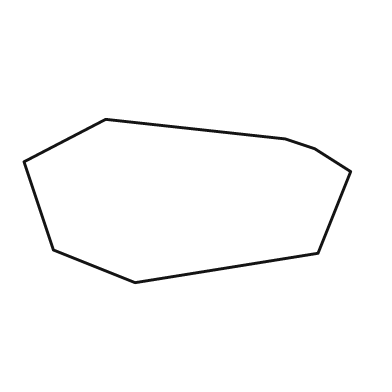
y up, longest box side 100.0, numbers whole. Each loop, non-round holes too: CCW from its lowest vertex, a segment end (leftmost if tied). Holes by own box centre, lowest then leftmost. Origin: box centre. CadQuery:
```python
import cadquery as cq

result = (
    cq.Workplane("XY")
    .moveTo(-16.0, -25.0)
    .lineTo(40.0, -16.0)
    .lineTo(50.0, 9.0)
    .lineTo(39.0, 16.0)
    .lineTo(30.0, 19.0)
    .lineTo(-25.0, 25.0)
    .lineTo(-50.0, 12.0)
    .lineTo(-41.0, -15.0)
    .close()
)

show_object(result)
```